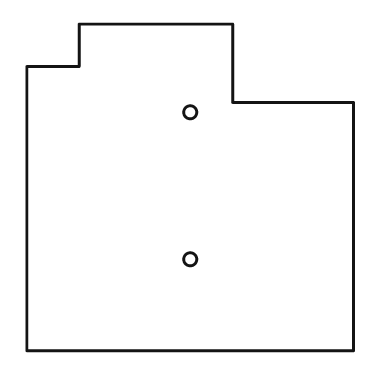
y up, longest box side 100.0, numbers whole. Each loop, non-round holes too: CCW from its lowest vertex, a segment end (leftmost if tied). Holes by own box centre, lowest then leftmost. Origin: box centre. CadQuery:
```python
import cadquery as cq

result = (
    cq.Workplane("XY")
    .moveTo(-50.0, -50.0)
    .lineTo(50.0, -50.0)
    .lineTo(50.0, 26.0)
    .lineTo(13.0, 26.0)
    .lineTo(13.0, 50.0)
    .lineTo(-34.0, 50.0)
    .lineTo(-34.0, 37.0)
    .lineTo(-50.0, 37.0)
    .close()
    .moveTo(0.0, -22.0)
    .circle(2.0)
    .moveTo(0.0, 23.0)
    .circle(2.0)
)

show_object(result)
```